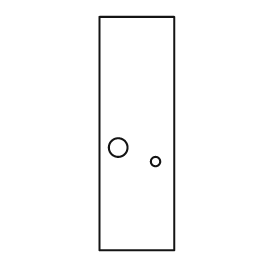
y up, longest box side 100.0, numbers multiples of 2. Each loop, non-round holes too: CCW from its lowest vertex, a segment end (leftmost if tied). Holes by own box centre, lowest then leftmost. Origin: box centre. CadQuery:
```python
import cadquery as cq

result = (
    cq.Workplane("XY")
    .moveTo(-16.0, -50.0)
    .lineTo(16.0, -50.0)
    .lineTo(16.0, 50.0)
    .lineTo(-16.0, 50.0)
    .close()
    .moveTo(8.0, -12.0)
    .circle(2.0)
    .moveTo(-8.0, -6.0)
    .circle(4.0)
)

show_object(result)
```